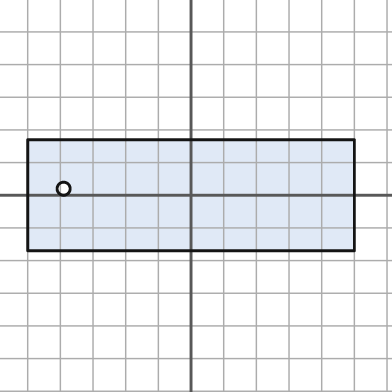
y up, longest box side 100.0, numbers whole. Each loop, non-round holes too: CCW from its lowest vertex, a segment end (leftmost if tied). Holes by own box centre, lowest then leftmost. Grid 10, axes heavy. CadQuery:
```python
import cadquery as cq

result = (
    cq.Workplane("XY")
    .moveTo(-50.0, -17.0)
    .lineTo(50.0, -17.0)
    .lineTo(50.0, 17.0)
    .lineTo(-50.0, 17.0)
    .close()
    .moveTo(-39.0, 2.0)
    .circle(2.0)
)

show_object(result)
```